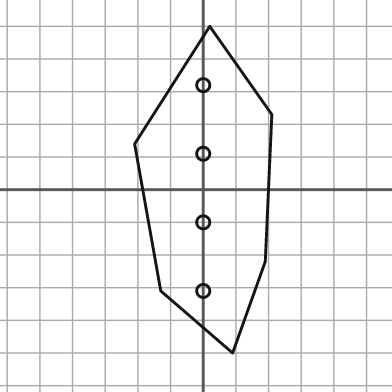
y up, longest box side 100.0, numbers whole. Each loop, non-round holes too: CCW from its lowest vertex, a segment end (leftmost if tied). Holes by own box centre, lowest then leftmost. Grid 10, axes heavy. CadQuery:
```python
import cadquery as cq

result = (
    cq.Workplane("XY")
    .moveTo(9.0, -50.0)
    .lineTo(19.0, -22.0)
    .lineTo(21.0, 23.0)
    .lineTo(2.0, 50.0)
    .lineTo(-21.0, 14.0)
    .lineTo(-13.0, -31.0)
    .close()
    .moveTo(0.0, -31.0)
    .circle(2.0)
    .moveTo(0.0, -10.0)
    .circle(2.0)
    .moveTo(0.0, 11.0)
    .circle(2.0)
    .moveTo(0.0, 32.0)
    .circle(2.0)
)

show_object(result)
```